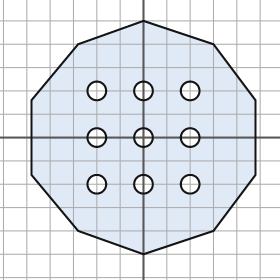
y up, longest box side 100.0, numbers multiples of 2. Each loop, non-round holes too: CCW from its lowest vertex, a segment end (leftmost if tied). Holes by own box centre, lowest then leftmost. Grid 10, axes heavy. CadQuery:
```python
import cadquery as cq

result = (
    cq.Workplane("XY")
    .moveTo(0.0, -50.0)
    .lineTo(30.0, -40.0)
    .lineTo(48.0, -16.0)
    .lineTo(48.0, 16.0)
    .lineTo(30.0, 40.0)
    .lineTo(0.0, 50.0)
    .lineTo(-28.0, 40.0)
    .lineTo(-48.0, 16.0)
    .lineTo(-48.0, -16.0)
    .lineTo(-28.0, -40.0)
    .close()
    .moveTo(-20.0, -20.0)
    .circle(4.0)
    .moveTo(0.0, -20.0)
    .circle(4.0)
    .moveTo(20.0, -20.0)
    .circle(4.0)
    .moveTo(-20.0, 0.0)
    .circle(4.0)
    .moveTo(0.0, 0.0)
    .circle(4.0)
    .moveTo(20.0, 0.0)
    .circle(4.0)
    .moveTo(-20.0, 20.0)
    .circle(4.0)
    .moveTo(0.0, 20.0)
    .circle(4.0)
    .moveTo(20.0, 20.0)
    .circle(4.0)
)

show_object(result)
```